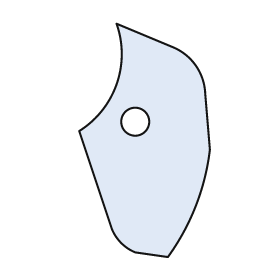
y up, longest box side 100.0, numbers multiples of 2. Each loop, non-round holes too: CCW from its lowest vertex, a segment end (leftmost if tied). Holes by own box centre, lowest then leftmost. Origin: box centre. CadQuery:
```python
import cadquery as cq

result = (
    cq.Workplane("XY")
    .moveTo(10.0, -50.0)
    .threePointArc((22.0, -28.0), (28.0, -4.0))
    .lineTo(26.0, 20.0)
    .threePointArc((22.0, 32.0), (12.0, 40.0))
    .lineTo(-12.0, 50.0)
    .threePointArc((-12.0, 24.0), (-28.0, 4.0))
    .lineTo(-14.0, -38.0)
    .threePointArc((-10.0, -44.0), (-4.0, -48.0))
    .close()
    .moveTo(-4.0, 8.0)
    .circle(6.0)
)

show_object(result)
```